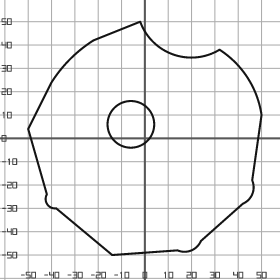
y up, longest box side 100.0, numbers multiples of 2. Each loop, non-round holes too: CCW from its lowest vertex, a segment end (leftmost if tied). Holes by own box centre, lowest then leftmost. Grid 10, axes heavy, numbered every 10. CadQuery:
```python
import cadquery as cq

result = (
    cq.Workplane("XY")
    .moveTo(-14.0, -50.0)
    .lineTo(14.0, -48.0)
    .threePointArc((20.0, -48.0), (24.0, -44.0))
    .lineTo(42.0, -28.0)
    .threePointArc((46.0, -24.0), (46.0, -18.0))
    .lineTo(50.0, 10.0)
    .threePointArc((44.0, 26.0), (32.0, 38.0))
    .threePointArc((12.0, 36.0), (-2.0, 50.0))
    .lineTo(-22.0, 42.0)
    .threePointArc((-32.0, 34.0), (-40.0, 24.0))
    .lineTo(-50.0, 4.0)
    .lineTo(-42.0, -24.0)
    .threePointArc((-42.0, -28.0), (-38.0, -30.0))
    .close()
    .moveTo(-6.0, 6.0)
    .circle(10.0)
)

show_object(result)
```